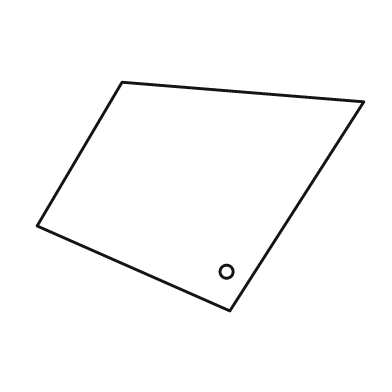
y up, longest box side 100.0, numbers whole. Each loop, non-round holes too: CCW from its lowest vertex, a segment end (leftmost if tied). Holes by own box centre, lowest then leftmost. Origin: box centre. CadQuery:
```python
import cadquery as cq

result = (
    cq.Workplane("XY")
    .moveTo(9.0, -35.0)
    .lineTo(50.0, 29.0)
    .lineTo(-24.0, 35.0)
    .lineTo(-50.0, -9.0)
    .close()
    .moveTo(8.0, -23.0)
    .circle(2.0)
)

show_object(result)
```